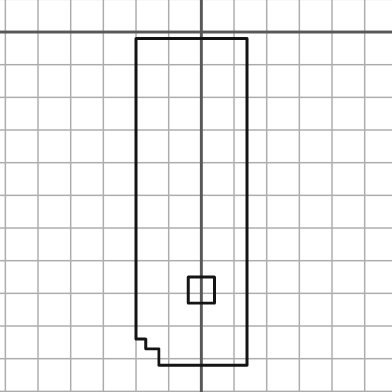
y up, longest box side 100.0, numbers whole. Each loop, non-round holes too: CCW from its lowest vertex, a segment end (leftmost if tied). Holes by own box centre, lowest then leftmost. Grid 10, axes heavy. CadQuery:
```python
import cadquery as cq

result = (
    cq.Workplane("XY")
    .moveTo(-13.0, -102.0)
    .lineTo(14.0, -102.0)
    .lineTo(14.0, -2.0)
    .lineTo(-20.0, -2.0)
    .lineTo(-20.0, -94.0)
    .lineTo(-17.0, -94.0)
    .lineTo(-17.0, -97.0)
    .lineTo(-13.0, -97.0)
    .close()
    .moveTo(-4.0, -83.0)
    .lineTo(4.0, -83.0)
    .lineTo(4.0, -75.0)
    .lineTo(-4.0, -75.0)
    .close()
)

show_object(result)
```